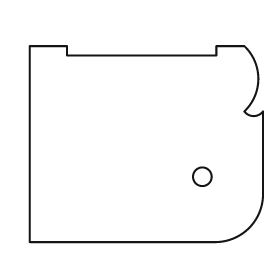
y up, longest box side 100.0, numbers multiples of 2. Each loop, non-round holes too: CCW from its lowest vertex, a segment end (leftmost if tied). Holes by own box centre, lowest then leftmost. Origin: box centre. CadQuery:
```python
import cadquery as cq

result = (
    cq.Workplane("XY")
    .moveTo(-50.0, -42.0)
    .lineTo(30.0, -42.0)
    .threePointArc((44.0, -36.0), (50.0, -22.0))
    .lineTo(50.0, 14.0)
    .threePointArc((46.0, 12.0), (42.0, 14.0))
    .threePointArc((48.0, 28.0), (42.0, 42.0))
    .lineTo(30.0, 42.0)
    .lineTo(30.0, 38.0)
    .lineTo(-34.0, 38.0)
    .lineTo(-34.0, 42.0)
    .lineTo(-50.0, 42.0)
    .close()
    .moveTo(24.0, -14.0)
    .circle(4.0)
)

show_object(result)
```